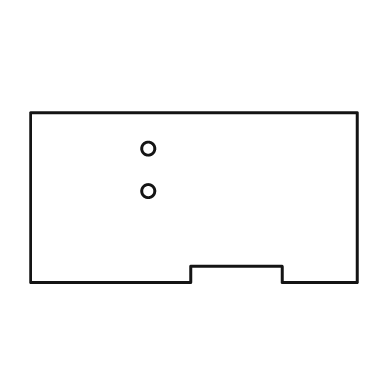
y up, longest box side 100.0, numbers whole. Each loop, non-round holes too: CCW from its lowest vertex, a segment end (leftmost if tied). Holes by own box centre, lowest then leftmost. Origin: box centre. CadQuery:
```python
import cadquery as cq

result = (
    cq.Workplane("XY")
    .moveTo(-50.0, -26.0)
    .lineTo(-1.0, -26.0)
    .lineTo(-1.0, -21.0)
    .lineTo(27.0, -21.0)
    .lineTo(27.0, -26.0)
    .lineTo(50.0, -26.0)
    .lineTo(50.0, 26.0)
    .lineTo(-50.0, 26.0)
    .close()
    .moveTo(-14.0, 2.0)
    .circle(2.0)
    .moveTo(-14.0, 15.0)
    .circle(2.0)
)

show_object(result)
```